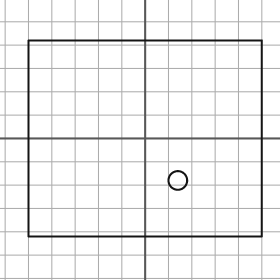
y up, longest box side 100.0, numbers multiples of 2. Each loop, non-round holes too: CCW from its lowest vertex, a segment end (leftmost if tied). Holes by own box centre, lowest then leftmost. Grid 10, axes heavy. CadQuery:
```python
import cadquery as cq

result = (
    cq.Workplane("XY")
    .moveTo(-50.0, -42.0)
    .lineTo(50.0, -42.0)
    .lineTo(50.0, 42.0)
    .lineTo(-50.0, 42.0)
    .close()
    .moveTo(14.0, -18.0)
    .circle(4.0)
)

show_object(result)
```